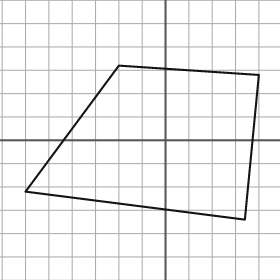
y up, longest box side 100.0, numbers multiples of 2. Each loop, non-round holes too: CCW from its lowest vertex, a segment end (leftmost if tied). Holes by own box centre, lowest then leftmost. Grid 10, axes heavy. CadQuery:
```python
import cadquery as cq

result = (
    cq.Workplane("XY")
    .moveTo(34.0, -34.0)
    .lineTo(40.0, 28.0)
    .lineTo(-20.0, 32.0)
    .lineTo(-60.0, -22.0)
    .close()
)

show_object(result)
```